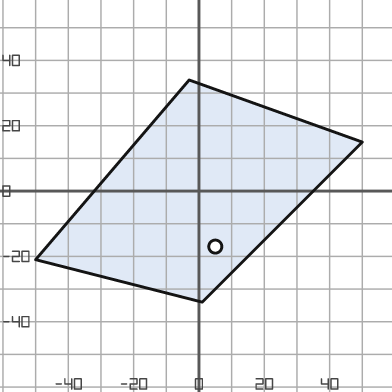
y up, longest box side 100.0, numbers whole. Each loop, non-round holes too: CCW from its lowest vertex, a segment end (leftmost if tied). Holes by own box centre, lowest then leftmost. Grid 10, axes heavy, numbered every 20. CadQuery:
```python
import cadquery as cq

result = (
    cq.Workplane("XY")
    .moveTo(1.0, -34.0)
    .lineTo(50.0, 15.0)
    .lineTo(-3.0, 34.0)
    .lineTo(-50.0, -21.0)
    .close()
    .moveTo(5.0, -17.0)
    .circle(2.0)
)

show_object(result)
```